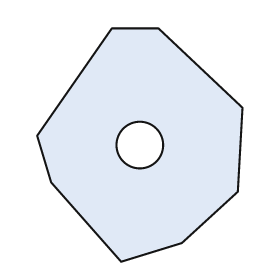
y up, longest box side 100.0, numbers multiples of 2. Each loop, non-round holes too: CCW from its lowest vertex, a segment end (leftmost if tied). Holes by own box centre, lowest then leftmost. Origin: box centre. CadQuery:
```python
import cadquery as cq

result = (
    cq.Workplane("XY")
    .moveTo(-8.0, -50.0)
    .lineTo(18.0, -42.0)
    .lineTo(42.0, -20.0)
    .lineTo(44.0, 16.0)
    .lineTo(8.0, 50.0)
    .lineTo(-12.0, 50.0)
    .lineTo(-44.0, 4.0)
    .lineTo(-38.0, -16.0)
    .close()
    .moveTo(0.0, 0.0)
    .circle(10.0)
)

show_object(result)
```